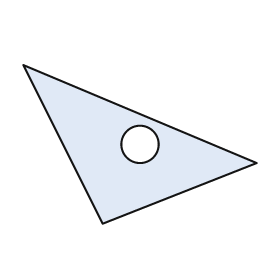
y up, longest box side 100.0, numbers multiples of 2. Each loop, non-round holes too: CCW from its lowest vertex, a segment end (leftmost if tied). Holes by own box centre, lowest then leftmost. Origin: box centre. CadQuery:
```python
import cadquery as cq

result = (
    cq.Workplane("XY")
    .moveTo(-16.0, -34.0)
    .lineTo(50.0, -8.0)
    .lineTo(-50.0, 34.0)
    .close()
    .moveTo(0.0, 0.0)
    .circle(8.0)
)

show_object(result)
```